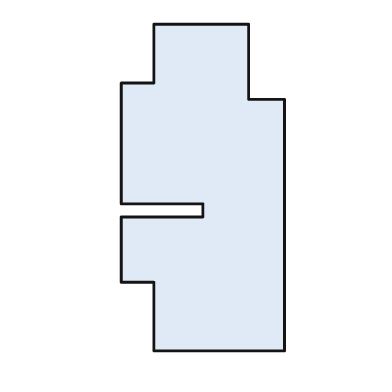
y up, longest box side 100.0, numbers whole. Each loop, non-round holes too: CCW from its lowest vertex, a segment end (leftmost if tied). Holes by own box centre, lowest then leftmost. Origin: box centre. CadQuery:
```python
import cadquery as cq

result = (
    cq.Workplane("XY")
    .moveTo(-15.0, -50.0)
    .lineTo(25.0, -50.0)
    .lineTo(25.0, 27.0)
    .lineTo(14.0, 27.0)
    .lineTo(14.0, 50.0)
    .lineTo(-15.0, 50.0)
    .lineTo(-15.0, 32.0)
    .lineTo(-25.0, 32.0)
    .lineTo(-25.0, -5.0)
    .lineTo(0.0, -5.0)
    .lineTo(0.0, -9.0)
    .lineTo(-25.0, -9.0)
    .lineTo(-25.0, -29.0)
    .lineTo(-15.0, -29.0)
    .close()
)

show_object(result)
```